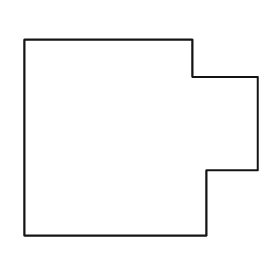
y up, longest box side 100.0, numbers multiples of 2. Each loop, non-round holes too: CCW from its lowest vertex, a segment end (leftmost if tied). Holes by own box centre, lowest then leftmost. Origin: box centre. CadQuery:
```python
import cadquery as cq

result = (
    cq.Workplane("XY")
    .moveTo(-50.0, -42.0)
    .lineTo(28.0, -42.0)
    .lineTo(28.0, -14.0)
    .lineTo(50.0, -14.0)
    .lineTo(50.0, 26.0)
    .lineTo(22.0, 26.0)
    .lineTo(22.0, 42.0)
    .lineTo(-50.0, 42.0)
    .close()
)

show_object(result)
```